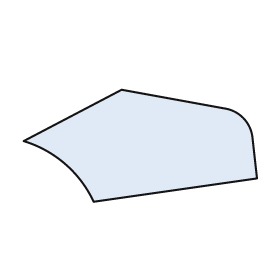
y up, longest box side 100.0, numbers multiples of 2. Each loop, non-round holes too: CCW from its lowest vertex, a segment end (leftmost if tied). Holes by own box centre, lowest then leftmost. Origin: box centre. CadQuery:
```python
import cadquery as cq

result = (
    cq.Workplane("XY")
    .moveTo(-20.0, -24.0)
    .lineTo(50.0, -14.0)
    .lineTo(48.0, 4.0)
    .threePointArc((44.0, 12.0), (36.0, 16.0))
    .lineTo(-8.0, 24.0)
    .lineTo(-50.0, 2.0)
    .threePointArc((-32.0, -8.0), (-20.0, -24.0))
    .close()
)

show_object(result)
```